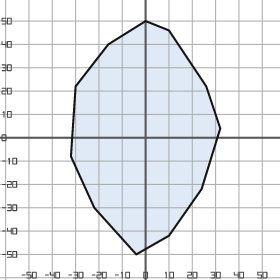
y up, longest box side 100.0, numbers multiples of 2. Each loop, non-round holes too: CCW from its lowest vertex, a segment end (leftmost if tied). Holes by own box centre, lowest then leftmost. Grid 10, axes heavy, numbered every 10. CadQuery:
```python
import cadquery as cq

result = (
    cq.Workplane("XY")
    .moveTo(-4.0, -50.0)
    .lineTo(10.0, -42.0)
    .lineTo(24.0, -22.0)
    .lineTo(32.0, 4.0)
    .lineTo(26.0, 22.0)
    .lineTo(10.0, 46.0)
    .lineTo(0.0, 50.0)
    .lineTo(-16.0, 40.0)
    .lineTo(-30.0, 22.0)
    .lineTo(-32.0, -8.0)
    .lineTo(-22.0, -30.0)
    .close()
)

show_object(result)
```